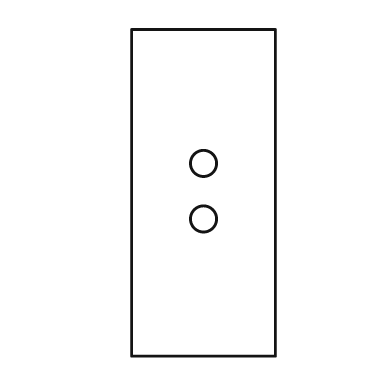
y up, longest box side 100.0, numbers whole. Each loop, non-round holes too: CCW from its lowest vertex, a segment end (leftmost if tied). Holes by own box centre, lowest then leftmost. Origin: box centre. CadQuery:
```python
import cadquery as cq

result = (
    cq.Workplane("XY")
    .moveTo(-22.0, -50.0)
    .lineTo(22.0, -50.0)
    .lineTo(22.0, 50.0)
    .lineTo(-22.0, 50.0)
    .close()
    .moveTo(0.0, -8.0)
    .circle(4.0)
    .moveTo(0.0, 9.0)
    .circle(4.0)
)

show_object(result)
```